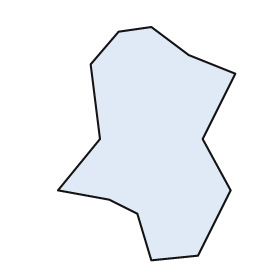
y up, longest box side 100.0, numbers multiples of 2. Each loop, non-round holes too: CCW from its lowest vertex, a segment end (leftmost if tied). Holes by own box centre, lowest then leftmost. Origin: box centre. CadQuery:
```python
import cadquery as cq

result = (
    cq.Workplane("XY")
    .moveTo(2.0, -50.0)
    .lineTo(22.0, -48.0)
    .lineTo(36.0, -20.0)
    .lineTo(24.0, 2.0)
    .lineTo(38.0, 30.0)
    .lineTo(18.0, 38.0)
    .lineTo(2.0, 50.0)
    .lineTo(-12.0, 48.0)
    .lineTo(-24.0, 34.0)
    .lineTo(-20.0, 2.0)
    .lineTo(-38.0, -20.0)
    .lineTo(-16.0, -24.0)
    .lineTo(-4.0, -30.0)
    .close()
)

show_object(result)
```